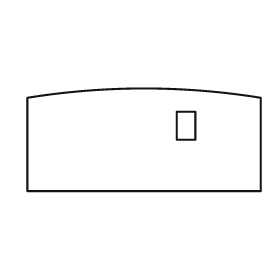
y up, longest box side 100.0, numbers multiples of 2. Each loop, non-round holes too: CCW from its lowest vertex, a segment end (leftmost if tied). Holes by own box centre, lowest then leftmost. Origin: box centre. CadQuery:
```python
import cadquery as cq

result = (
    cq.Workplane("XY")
    .moveTo(-50.0, -22.0)
    .lineTo(50.0, -22.0)
    .lineTo(50.0, 18.0)
    .threePointArc((0.0, 22.0), (-50.0, 18.0))
    .close()
    .moveTo(14.0, 0.0)
    .lineTo(22.0, 0.0)
    .lineTo(22.0, 12.0)
    .lineTo(14.0, 12.0)
    .close()
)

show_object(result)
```